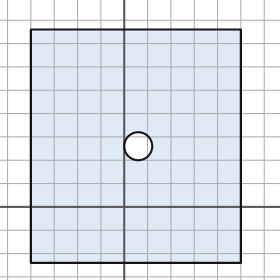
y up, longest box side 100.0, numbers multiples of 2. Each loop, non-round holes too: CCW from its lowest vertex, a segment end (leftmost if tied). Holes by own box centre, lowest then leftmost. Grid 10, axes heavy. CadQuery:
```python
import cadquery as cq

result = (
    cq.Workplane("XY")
    .moveTo(-40.0, -24.0)
    .lineTo(50.0, -24.0)
    .lineTo(50.0, 76.0)
    .lineTo(-40.0, 76.0)
    .close()
    .moveTo(6.0, 26.0)
    .circle(6.0)
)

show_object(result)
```